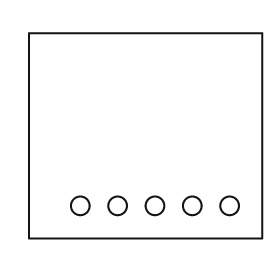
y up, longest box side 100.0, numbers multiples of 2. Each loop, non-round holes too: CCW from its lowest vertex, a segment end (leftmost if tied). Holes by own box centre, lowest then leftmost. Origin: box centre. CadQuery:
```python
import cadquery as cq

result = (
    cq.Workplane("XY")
    .moveTo(-50.0, -44.0)
    .lineTo(50.0, -44.0)
    .lineTo(50.0, 44.0)
    .lineTo(-50.0, 44.0)
    .close()
    .moveTo(-28.0, -30.0)
    .circle(4.0)
    .moveTo(-12.0, -30.0)
    .circle(4.0)
    .moveTo(4.0, -30.0)
    .circle(4.0)
    .moveTo(20.0, -30.0)
    .circle(4.0)
    .moveTo(36.0, -30.0)
    .circle(4.0)
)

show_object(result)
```